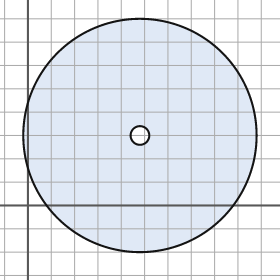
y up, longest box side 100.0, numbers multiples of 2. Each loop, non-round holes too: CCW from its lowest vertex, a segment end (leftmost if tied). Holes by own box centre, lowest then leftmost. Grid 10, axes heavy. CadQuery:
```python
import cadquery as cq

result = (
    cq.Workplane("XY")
    .moveTo(48.0, 30.0)
    .circle(50.0)
    .moveTo(48.0, 30.0)
    .circle(4.0)
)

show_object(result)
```